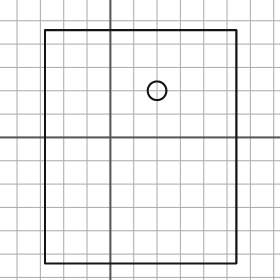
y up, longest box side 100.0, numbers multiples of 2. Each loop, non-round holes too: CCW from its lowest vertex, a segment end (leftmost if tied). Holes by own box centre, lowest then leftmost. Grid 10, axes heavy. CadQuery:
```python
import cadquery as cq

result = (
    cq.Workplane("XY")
    .moveTo(-28.0, -54.0)
    .lineTo(54.0, -54.0)
    .lineTo(54.0, 46.0)
    .lineTo(-28.0, 46.0)
    .close()
    .moveTo(20.0, 20.0)
    .circle(4.0)
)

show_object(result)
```